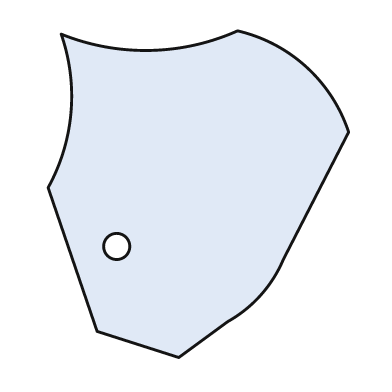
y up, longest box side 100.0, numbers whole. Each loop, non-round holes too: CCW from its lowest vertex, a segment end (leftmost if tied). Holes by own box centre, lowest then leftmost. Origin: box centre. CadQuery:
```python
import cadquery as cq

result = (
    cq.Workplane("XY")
    .moveTo(-6.0, -50.0)
    .lineTo(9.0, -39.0)
    .threePointArc((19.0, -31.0), (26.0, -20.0))
    .lineTo(46.0, 19.0)
    .threePointArc((33.0, 39.0), (12.0, 50.0))
    .threePointArc((-15.0, 44.0), (-42.0, 49.0))
    .threePointArc((-39.0, 25.0), (-46.0, 2.0))
    .lineTo(-31.0, -42.0)
    .close()
    .moveTo(-25.0, -16.0)
    .circle(4.0)
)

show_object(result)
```